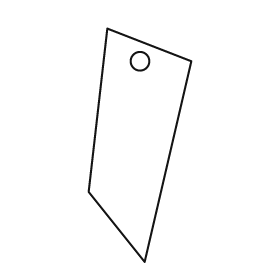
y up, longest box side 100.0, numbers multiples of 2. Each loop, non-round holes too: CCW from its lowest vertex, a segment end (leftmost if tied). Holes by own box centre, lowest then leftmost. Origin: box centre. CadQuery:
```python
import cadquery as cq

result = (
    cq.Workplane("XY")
    .moveTo(2.0, -50.0)
    .lineTo(22.0, 36.0)
    .lineTo(-14.0, 50.0)
    .lineTo(-22.0, -20.0)
    .close()
    .moveTo(0.0, 36.0)
    .circle(4.0)
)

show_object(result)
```